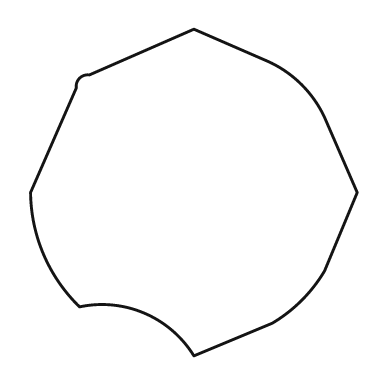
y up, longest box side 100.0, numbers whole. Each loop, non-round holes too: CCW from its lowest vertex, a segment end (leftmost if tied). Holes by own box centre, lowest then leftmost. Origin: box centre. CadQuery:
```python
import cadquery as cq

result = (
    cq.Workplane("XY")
    .moveTo(0.0, -50.0)
    .lineTo(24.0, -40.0)
    .threePointArc((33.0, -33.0), (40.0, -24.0))
    .lineTo(50.0, 0.0)
    .lineTo(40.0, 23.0)
    .threePointArc((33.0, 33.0), (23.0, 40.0))
    .lineTo(0.0, 50.0)
    .lineTo(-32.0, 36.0)
    .threePointArc((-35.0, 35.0), (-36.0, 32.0))
    .lineTo(-50.0, 0.0)
    .threePointArc((-46.0, -19.0), (-35.0, -35.0))
    .threePointArc((-15.0, -37.0), (0.0, -50.0))
    .close()
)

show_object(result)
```